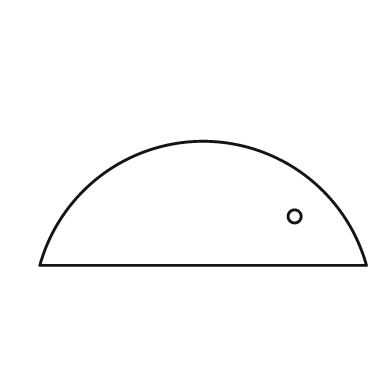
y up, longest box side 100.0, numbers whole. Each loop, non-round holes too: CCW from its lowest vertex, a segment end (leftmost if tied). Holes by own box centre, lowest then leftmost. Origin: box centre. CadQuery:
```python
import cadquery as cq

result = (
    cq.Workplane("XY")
    .moveTo(-50.0, -19.0)
    .lineTo(50.0, -19.0)
    .threePointArc((0.0, 19.0), (-50.0, -19.0))
    .close()
    .moveTo(28.0, -4.0)
    .circle(2.0)
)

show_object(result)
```